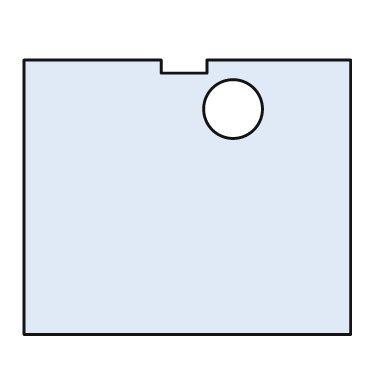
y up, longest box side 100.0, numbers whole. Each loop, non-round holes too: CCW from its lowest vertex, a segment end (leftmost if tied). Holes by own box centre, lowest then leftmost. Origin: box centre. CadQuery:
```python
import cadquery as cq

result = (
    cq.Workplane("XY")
    .moveTo(-50.0, -42.0)
    .lineTo(50.0, -42.0)
    .lineTo(50.0, 42.0)
    .lineTo(6.0, 42.0)
    .lineTo(6.0, 38.0)
    .lineTo(-8.0, 38.0)
    .lineTo(-8.0, 42.0)
    .lineTo(-50.0, 42.0)
    .close()
    .moveTo(14.0, 27.0)
    .circle(9.0)
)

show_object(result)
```